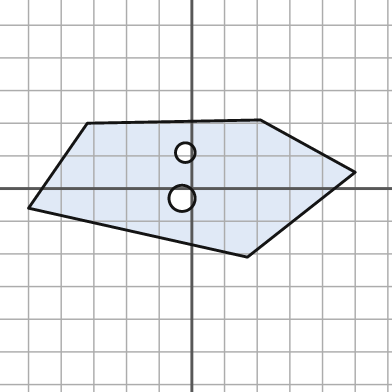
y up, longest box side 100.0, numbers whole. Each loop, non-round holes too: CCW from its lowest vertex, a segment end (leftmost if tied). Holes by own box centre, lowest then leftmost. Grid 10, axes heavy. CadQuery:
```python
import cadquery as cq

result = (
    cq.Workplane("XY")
    .moveTo(17.0, -21.0)
    .lineTo(50.0, 5.0)
    .lineTo(21.0, 21.0)
    .lineTo(-32.0, 20.0)
    .lineTo(-50.0, -6.0)
    .close()
    .moveTo(-3.0, -3.0)
    .circle(4.0)
    .moveTo(-2.0, 11.0)
    .circle(3.0)
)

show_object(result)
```